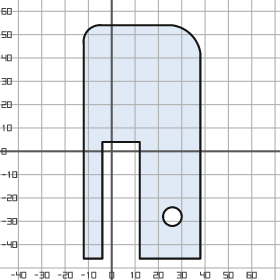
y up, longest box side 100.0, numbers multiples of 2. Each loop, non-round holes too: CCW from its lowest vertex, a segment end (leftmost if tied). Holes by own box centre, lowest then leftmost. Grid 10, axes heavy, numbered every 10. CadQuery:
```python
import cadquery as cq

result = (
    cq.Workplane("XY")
    .moveTo(-12.0, -46.0)
    .lineTo(-4.0, -46.0)
    .lineTo(-4.0, 4.0)
    .lineTo(12.0, 4.0)
    .lineTo(12.0, -46.0)
    .lineTo(38.0, -46.0)
    .lineTo(38.0, 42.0)
    .threePointArc((34.0, 50.0), (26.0, 54.0))
    .lineTo(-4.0, 54.0)
    .threePointArc((-10.0, 52.0), (-12.0, 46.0))
    .close()
    .moveTo(26.0, -28.0)
    .circle(4.0)
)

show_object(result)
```